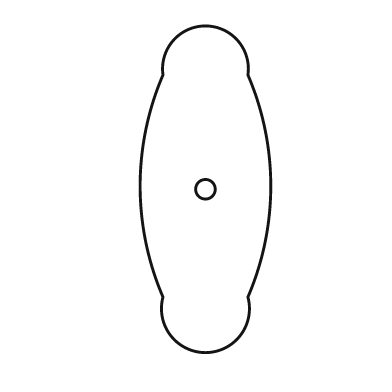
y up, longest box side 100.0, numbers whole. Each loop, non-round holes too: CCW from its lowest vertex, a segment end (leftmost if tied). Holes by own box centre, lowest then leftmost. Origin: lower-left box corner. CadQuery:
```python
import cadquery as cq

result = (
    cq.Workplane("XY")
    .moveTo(7.0, 17.0)
    .threePointArc((20.0, 0.0), (33.0, 17.0))
    .threePointArc((40.0, 51.0), (33.0, 85.0))
    .threePointArc((20.0, 100.0), (7.0, 85.0))
    .threePointArc((0.0, 51.0), (7.0, 17.0))
    .close()
    .moveTo(20.0, 50.0)
    .circle(3.0)
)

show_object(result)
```